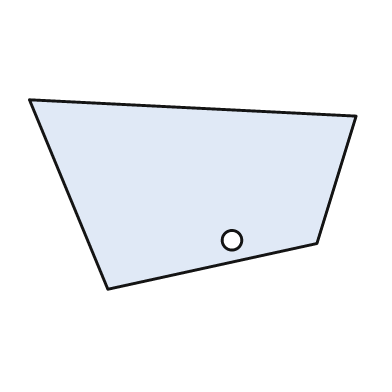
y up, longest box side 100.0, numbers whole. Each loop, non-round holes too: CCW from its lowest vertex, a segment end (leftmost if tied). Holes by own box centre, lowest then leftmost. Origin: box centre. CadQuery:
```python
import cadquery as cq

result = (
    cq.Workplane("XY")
    .moveTo(-26.0, -29.0)
    .lineTo(38.0, -15.0)
    .lineTo(50.0, 24.0)
    .lineTo(-50.0, 29.0)
    .close()
    .moveTo(12.0, -14.0)
    .circle(3.0)
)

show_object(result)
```